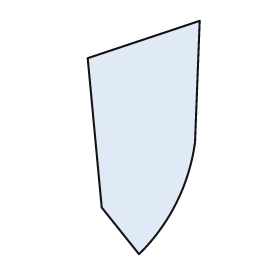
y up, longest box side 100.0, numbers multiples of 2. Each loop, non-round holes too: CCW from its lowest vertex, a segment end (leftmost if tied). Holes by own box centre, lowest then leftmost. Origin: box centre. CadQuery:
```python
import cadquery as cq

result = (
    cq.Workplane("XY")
    .moveTo(-2.0, -50.0)
    .threePointArc((14.0, -28.0), (22.0, -2.0))
    .lineTo(24.0, 50.0)
    .lineTo(-24.0, 34.0)
    .lineTo(-18.0, -30.0)
    .close()
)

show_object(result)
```